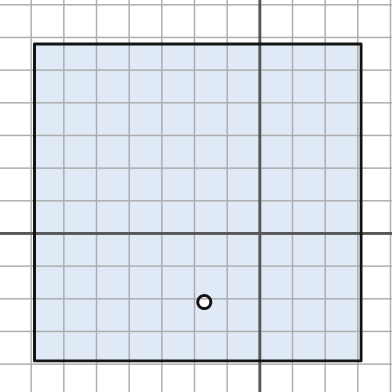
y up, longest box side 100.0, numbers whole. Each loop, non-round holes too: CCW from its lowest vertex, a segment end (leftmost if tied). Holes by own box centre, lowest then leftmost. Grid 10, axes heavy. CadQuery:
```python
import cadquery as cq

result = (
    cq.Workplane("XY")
    .moveTo(-69.0, -39.0)
    .lineTo(31.0, -39.0)
    .lineTo(31.0, 58.0)
    .lineTo(-69.0, 58.0)
    .close()
    .moveTo(-17.0, -21.0)
    .circle(2.0)
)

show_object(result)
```